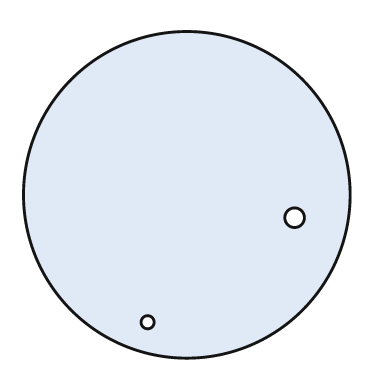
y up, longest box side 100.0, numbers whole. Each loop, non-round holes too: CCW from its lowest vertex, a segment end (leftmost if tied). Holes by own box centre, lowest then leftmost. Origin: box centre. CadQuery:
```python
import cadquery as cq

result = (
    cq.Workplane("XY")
    .moveTo(0.0, 0.0)
    .circle(50.0)
    .moveTo(-12.0, -39.0)
    .circle(2.0)
    .moveTo(33.0, -7.0)
    .circle(3.0)
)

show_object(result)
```